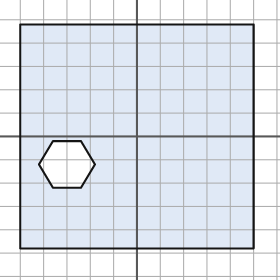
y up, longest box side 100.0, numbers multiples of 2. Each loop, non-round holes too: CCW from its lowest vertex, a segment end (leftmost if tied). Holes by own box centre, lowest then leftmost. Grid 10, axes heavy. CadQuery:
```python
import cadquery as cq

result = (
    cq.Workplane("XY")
    .moveTo(-50.0, -48.0)
    .lineTo(50.0, -48.0)
    .lineTo(50.0, 48.0)
    .lineTo(-50.0, 48.0)
    .close()
    .moveTo(-36.0, -22.0)
    .lineTo(-24.0, -22.0)
    .lineTo(-18.0, -12.0)
    .lineTo(-24.0, -2.0)
    .lineTo(-36.0, -2.0)
    .lineTo(-42.0, -12.0)
    .close()
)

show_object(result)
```